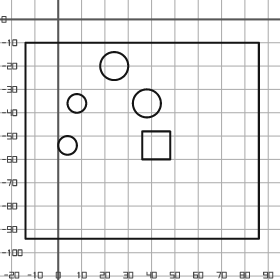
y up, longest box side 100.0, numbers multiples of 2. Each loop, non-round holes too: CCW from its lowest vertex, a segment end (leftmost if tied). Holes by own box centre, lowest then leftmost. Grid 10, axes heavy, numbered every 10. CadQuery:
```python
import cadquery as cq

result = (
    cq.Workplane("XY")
    .moveTo(-14.0, -94.0)
    .lineTo(86.0, -94.0)
    .lineTo(86.0, -10.0)
    .lineTo(-14.0, -10.0)
    .close()
    .moveTo(4.0, -54.0)
    .circle(4.0)
    .moveTo(36.0, -60.0)
    .lineTo(48.0, -60.0)
    .lineTo(48.0, -48.0)
    .lineTo(36.0, -48.0)
    .close()
    .moveTo(8.0, -36.0)
    .circle(4.0)
    .moveTo(38.0, -36.0)
    .circle(6.0)
    .moveTo(24.0, -20.0)
    .circle(6.0)
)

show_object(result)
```